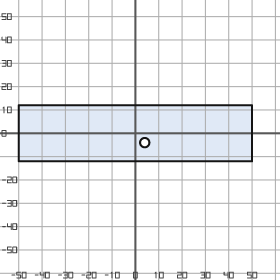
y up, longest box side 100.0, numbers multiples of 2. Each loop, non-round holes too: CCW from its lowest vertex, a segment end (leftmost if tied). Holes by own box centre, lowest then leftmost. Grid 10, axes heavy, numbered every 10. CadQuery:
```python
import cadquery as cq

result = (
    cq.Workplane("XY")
    .moveTo(-50.0, -12.0)
    .lineTo(50.0, -12.0)
    .lineTo(50.0, 12.0)
    .lineTo(-50.0, 12.0)
    .close()
    .moveTo(4.0, -4.0)
    .circle(2.0)
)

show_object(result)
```